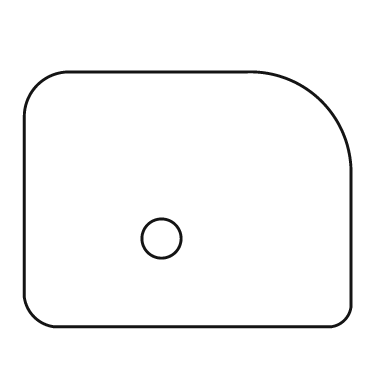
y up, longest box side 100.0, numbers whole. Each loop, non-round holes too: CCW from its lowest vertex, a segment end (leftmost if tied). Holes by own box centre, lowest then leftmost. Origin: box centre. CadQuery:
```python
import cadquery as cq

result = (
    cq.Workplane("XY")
    .moveTo(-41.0, -39.0)
    .lineTo(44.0, -39.0)
    .threePointArc((48.0, -37.0), (50.0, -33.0))
    .lineTo(50.0, 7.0)
    .threePointArc((41.0, 30.0), (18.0, 39.0))
    .lineTo(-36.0, 39.0)
    .threePointArc((-46.0, 35.0), (-50.0, 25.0))
    .lineTo(-50.0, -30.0)
    .threePointArc((-47.0, -36.0), (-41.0, -39.0))
    .close()
    .moveTo(-8.0, -12.0)
    .circle(6.0)
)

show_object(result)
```